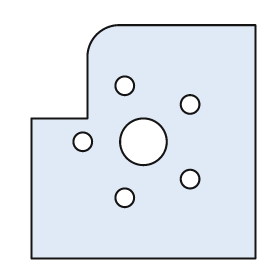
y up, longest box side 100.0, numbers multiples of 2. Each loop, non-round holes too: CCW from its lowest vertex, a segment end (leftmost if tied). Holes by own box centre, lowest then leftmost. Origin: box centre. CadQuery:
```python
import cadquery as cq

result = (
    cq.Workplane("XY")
    .moveTo(-48.0, -50.0)
    .lineTo(48.0, -50.0)
    .lineTo(48.0, 50.0)
    .lineTo(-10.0, 50.0)
    .threePointArc((-20.0, 46.0), (-24.0, 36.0))
    .lineTo(-24.0, 10.0)
    .lineTo(-48.0, 10.0)
    .close()
    .moveTo(-8.0, -24.0)
    .circle(4.0)
    .moveTo(20.0, -16.0)
    .circle(4.0)
    .moveTo(-26.0, 0.0)
    .circle(4.0)
    .moveTo(0.0, 0.0)
    .circle(10.0)
    .moveTo(20.0, 16.0)
    .circle(4.0)
    .moveTo(-8.0, 24.0)
    .circle(4.0)
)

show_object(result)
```